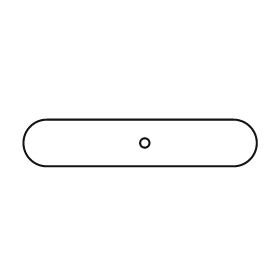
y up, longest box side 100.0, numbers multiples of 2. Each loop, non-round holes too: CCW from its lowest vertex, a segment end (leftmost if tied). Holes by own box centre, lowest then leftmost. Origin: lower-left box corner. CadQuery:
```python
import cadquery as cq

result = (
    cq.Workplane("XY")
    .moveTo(10.0, 0.0)
    .lineTo(90.0, 0.0)
    .threePointArc((100.0, 10.0), (90.0, 20.0))
    .lineTo(10.0, 20.0)
    .threePointArc((0.0, 10.0), (10.0, 0.0))
    .close()
    .moveTo(52.0, 10.0)
    .circle(2.0)
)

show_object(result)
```